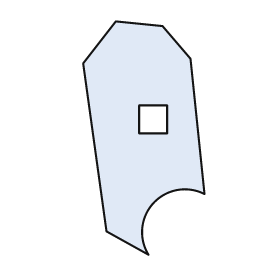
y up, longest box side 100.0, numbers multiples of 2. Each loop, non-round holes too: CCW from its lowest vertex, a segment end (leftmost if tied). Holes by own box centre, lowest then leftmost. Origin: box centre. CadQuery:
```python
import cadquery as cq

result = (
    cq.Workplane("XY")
    .moveTo(2.0, -50.0)
    .threePointArc((4.0, -28.0), (26.0, -24.0))
    .lineTo(20.0, 34.0)
    .lineTo(8.0, 48.0)
    .lineTo(-12.0, 50.0)
    .lineTo(-26.0, 32.0)
    .lineTo(-16.0, -40.0)
    .close()
    .moveTo(-2.0, 2.0)
    .lineTo(10.0, 2.0)
    .lineTo(10.0, 14.0)
    .lineTo(-2.0, 14.0)
    .close()
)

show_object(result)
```